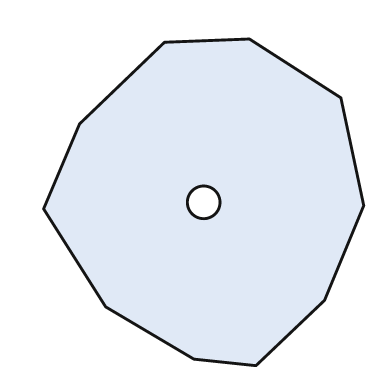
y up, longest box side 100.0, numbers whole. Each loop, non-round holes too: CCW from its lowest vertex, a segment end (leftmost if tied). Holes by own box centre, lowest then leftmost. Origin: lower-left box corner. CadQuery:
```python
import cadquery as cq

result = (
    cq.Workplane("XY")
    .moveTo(65.0, 0.0)
    .lineTo(86.0, 20.0)
    .lineTo(98.0, 49.0)
    .lineTo(91.0, 82.0)
    .lineTo(63.0, 100.0)
    .lineTo(37.0, 99.0)
    .lineTo(11.0, 74.0)
    .lineTo(0.0, 48.0)
    .lineTo(19.0, 18.0)
    .lineTo(46.0, 2.0)
    .close()
    .moveTo(49.0, 50.0)
    .circle(5.0)
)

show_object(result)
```